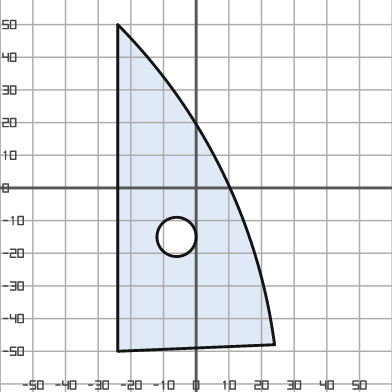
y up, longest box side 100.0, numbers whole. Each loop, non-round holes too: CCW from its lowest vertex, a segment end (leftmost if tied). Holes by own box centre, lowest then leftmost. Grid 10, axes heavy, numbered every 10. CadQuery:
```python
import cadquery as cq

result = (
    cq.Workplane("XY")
    .moveTo(-24.0, -50.0)
    .lineTo(24.0, -48.0)
    .threePointArc((8.0, 5.0), (-24.0, 50.0))
    .close()
    .moveTo(-6.0, -15.0)
    .circle(6.0)
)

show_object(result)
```